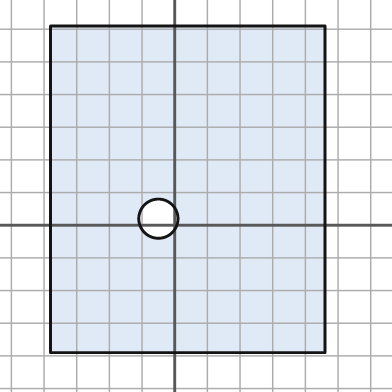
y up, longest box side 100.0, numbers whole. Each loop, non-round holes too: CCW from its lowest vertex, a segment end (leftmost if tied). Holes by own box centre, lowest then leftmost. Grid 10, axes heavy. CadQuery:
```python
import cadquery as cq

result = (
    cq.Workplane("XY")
    .moveTo(-38.0, -39.0)
    .lineTo(46.0, -39.0)
    .lineTo(46.0, 61.0)
    .lineTo(-38.0, 61.0)
    .close()
    .moveTo(-5.0, 2.0)
    .circle(6.0)
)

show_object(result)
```